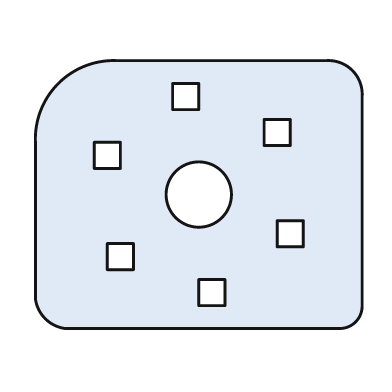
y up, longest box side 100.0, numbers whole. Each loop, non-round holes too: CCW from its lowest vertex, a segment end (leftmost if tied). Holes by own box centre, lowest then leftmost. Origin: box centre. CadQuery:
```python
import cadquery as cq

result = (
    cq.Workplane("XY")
    .moveTo(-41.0, -41.0)
    .lineTo(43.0, -41.0)
    .threePointArc((48.0, -39.0), (50.0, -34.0))
    .lineTo(50.0, 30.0)
    .threePointArc((47.0, 38.0), (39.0, 41.0))
    .lineTo(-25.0, 41.0)
    .threePointArc((-43.0, 34.0), (-50.0, 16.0))
    .lineTo(-50.0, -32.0)
    .threePointArc((-47.0, -38.0), (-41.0, -41.0))
    .close()
    .moveTo(0.0, -34.0)
    .lineTo(8.0, -34.0)
    .lineTo(8.0, -26.0)
    .lineTo(0.0, -26.0)
    .close()
    .moveTo(-28.0, -23.0)
    .lineTo(-20.0, -23.0)
    .lineTo(-20.0, -15.0)
    .lineTo(-28.0, -15.0)
    .close()
    .moveTo(24.0, -16.0)
    .lineTo(32.0, -16.0)
    .lineTo(32.0, -8.0)
    .lineTo(24.0, -8.0)
    .close()
    .moveTo(0.0, 0.0)
    .circle(10.0)
    .moveTo(-32.0, 8.0)
    .lineTo(-24.0, 8.0)
    .lineTo(-24.0, 16.0)
    .lineTo(-32.0, 16.0)
    .close()
    .moveTo(20.0, 15.0)
    .lineTo(28.0, 15.0)
    .lineTo(28.0, 23.0)
    .lineTo(20.0, 23.0)
    .close()
    .moveTo(-8.0, 26.0)
    .lineTo(0.0, 26.0)
    .lineTo(0.0, 34.0)
    .lineTo(-8.0, 34.0)
    .close()
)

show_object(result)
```